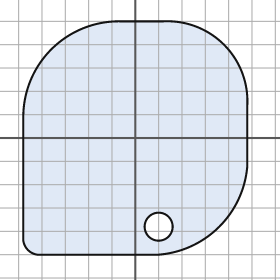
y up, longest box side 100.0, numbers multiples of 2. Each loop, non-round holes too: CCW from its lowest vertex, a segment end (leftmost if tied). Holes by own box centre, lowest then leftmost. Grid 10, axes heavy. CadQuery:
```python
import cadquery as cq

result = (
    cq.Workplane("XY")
    .moveTo(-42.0, -50.0)
    .lineTo(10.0, -50.0)
    .threePointArc((36.0, -38.0), (48.0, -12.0))
    .lineTo(48.0, 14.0)
    .threePointArc((38.0, 40.0), (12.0, 50.0))
    .lineTo(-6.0, 50.0)
    .threePointArc((-36.0, 38.0), (-48.0, 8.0))
    .lineTo(-48.0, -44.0)
    .threePointArc((-46.0, -48.0), (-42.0, -50.0))
    .close()
    .moveTo(10.0, -38.0)
    .circle(6.0)
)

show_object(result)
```